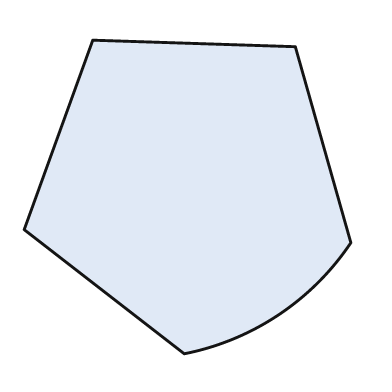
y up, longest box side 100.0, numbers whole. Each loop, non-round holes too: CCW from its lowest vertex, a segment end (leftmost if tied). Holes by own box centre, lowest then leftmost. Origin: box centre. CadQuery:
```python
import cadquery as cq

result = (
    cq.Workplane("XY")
    .moveTo(-1.0, -48.0)
    .threePointArc((28.0, -36.0), (50.0, -14.0))
    .lineTo(33.0, 46.0)
    .lineTo(-29.0, 48.0)
    .lineTo(-50.0, -10.0)
    .close()
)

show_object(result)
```